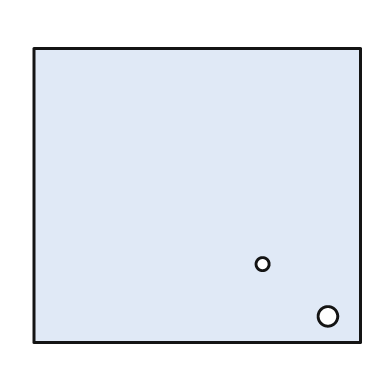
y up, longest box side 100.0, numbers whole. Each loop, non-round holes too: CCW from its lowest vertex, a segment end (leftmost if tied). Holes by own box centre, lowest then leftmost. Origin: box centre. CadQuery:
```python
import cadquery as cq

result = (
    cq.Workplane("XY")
    .moveTo(-50.0, -45.0)
    .lineTo(50.0, -45.0)
    .lineTo(50.0, 45.0)
    .lineTo(-50.0, 45.0)
    .close()
    .moveTo(40.0, -37.0)
    .circle(3.0)
    .moveTo(20.0, -21.0)
    .circle(2.0)
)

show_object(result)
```